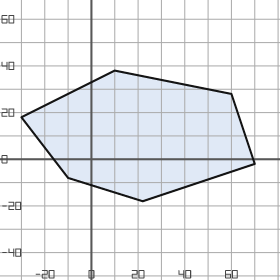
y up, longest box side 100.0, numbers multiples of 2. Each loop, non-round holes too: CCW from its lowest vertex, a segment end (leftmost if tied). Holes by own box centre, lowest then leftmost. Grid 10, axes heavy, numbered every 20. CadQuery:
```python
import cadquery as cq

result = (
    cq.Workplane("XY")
    .moveTo(22.0, -18.0)
    .lineTo(70.0, -2.0)
    .lineTo(60.0, 28.0)
    .lineTo(10.0, 38.0)
    .lineTo(-30.0, 18.0)
    .lineTo(-10.0, -8.0)
    .close()
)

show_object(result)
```